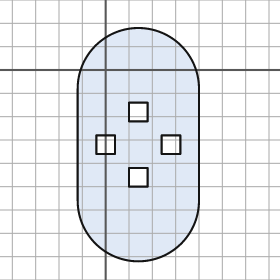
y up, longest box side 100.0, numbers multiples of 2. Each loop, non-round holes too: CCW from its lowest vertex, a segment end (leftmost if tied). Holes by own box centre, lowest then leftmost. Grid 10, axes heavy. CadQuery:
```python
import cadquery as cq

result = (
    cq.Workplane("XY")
    .moveTo(-12.0, -56.0)
    .threePointArc((14.0, -82.0), (40.0, -56.0))
    .lineTo(40.0, -8.0)
    .threePointArc((14.0, 18.0), (-12.0, -8.0))
    .close()
    .moveTo(10.0, -50.0)
    .lineTo(18.0, -50.0)
    .lineTo(18.0, -42.0)
    .lineTo(10.0, -42.0)
    .close()
    .moveTo(-4.0, -36.0)
    .lineTo(4.0, -36.0)
    .lineTo(4.0, -28.0)
    .lineTo(-4.0, -28.0)
    .close()
    .moveTo(24.0, -36.0)
    .lineTo(32.0, -36.0)
    .lineTo(32.0, -28.0)
    .lineTo(24.0, -28.0)
    .close()
    .moveTo(10.0, -22.0)
    .lineTo(18.0, -22.0)
    .lineTo(18.0, -14.0)
    .lineTo(10.0, -14.0)
    .close()
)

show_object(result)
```